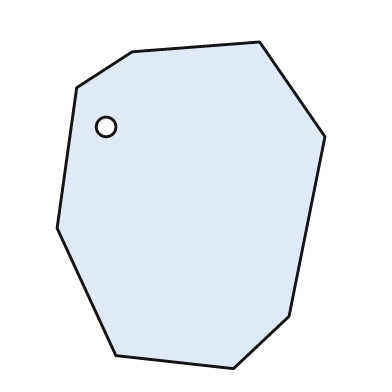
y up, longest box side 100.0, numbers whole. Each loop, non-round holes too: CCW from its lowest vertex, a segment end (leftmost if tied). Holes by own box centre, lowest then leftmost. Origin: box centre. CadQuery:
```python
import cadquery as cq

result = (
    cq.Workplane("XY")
    .moveTo(13.0, -50.0)
    .lineTo(30.0, -34.0)
    .lineTo(41.0, 21.0)
    .lineTo(21.0, 50.0)
    .lineTo(-18.0, 47.0)
    .lineTo(-35.0, 36.0)
    .lineTo(-41.0, -7.0)
    .lineTo(-23.0, -46.0)
    .close()
    .moveTo(-26.0, 24.0)
    .circle(3.0)
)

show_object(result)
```